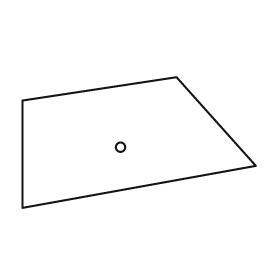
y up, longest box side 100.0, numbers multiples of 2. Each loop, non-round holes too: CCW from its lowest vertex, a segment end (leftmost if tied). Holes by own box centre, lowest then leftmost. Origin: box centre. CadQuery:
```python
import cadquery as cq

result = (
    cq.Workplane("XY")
    .moveTo(-50.0, -28.0)
    .lineTo(50.0, -10.0)
    .lineTo(16.0, 28.0)
    .lineTo(-50.0, 18.0)
    .close()
    .moveTo(-8.0, -2.0)
    .circle(2.0)
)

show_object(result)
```